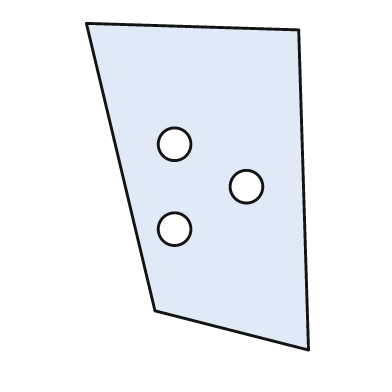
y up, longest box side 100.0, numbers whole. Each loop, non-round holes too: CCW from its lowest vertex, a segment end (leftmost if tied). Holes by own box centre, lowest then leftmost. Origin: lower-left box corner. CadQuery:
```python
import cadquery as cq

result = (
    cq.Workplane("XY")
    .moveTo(68.0, 0.0)
    .lineTo(65.0, 98.0)
    .lineTo(0.0, 100.0)
    .lineTo(21.0, 12.0)
    .close()
    .moveTo(27.0, 37.0)
    .circle(5.0)
    .moveTo(49.0, 50.0)
    .circle(5.0)
    .moveTo(27.0, 63.0)
    .circle(5.0)
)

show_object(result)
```